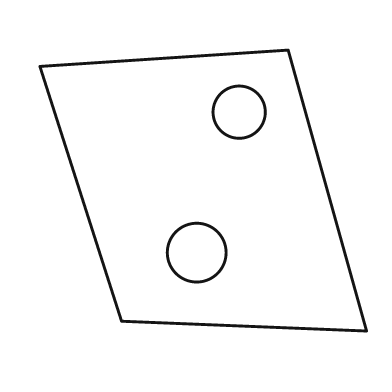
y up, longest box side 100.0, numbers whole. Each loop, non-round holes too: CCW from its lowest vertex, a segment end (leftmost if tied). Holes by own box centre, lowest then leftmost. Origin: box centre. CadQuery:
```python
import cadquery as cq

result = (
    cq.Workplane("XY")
    .moveTo(50.0, -43.0)
    .lineTo(26.0, 43.0)
    .lineTo(-50.0, 38.0)
    .lineTo(-25.0, -40.0)
    .close()
    .moveTo(-2.0, -19.0)
    .circle(9.0)
    .moveTo(11.0, 24.0)
    .circle(8.0)
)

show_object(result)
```